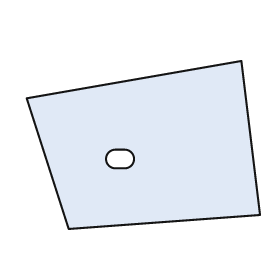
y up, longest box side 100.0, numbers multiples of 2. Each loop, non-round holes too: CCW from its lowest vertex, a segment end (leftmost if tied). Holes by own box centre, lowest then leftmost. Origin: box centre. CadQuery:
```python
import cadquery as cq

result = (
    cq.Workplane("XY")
    .moveTo(-32.0, -36.0)
    .lineTo(50.0, -30.0)
    .lineTo(42.0, 36.0)
    .lineTo(-50.0, 20.0)
    .close()
    .moveTo(-12.0, -10.0)
    .lineTo(-8.0, -10.0)
    .threePointArc((-4.0, -6.0), (-8.0, -2.0))
    .lineTo(-12.0, -2.0)
    .threePointArc((-16.0, -6.0), (-12.0, -10.0))
    .close()
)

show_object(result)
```